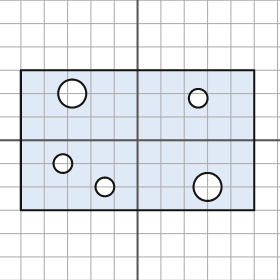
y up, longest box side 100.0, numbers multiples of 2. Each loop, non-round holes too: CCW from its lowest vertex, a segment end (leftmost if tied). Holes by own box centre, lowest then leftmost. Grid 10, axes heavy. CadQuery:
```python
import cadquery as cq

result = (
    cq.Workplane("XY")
    .moveTo(-50.0, -30.0)
    .lineTo(50.0, -30.0)
    .lineTo(50.0, 30.0)
    .lineTo(-50.0, 30.0)
    .close()
    .moveTo(-14.0, -20.0)
    .circle(4.0)
    .moveTo(30.0, -20.0)
    .circle(6.0)
    .moveTo(-32.0, -10.0)
    .circle(4.0)
    .moveTo(26.0, 18.0)
    .circle(4.0)
    .moveTo(-28.0, 20.0)
    .circle(6.0)
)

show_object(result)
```